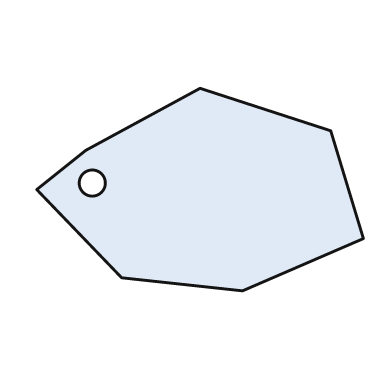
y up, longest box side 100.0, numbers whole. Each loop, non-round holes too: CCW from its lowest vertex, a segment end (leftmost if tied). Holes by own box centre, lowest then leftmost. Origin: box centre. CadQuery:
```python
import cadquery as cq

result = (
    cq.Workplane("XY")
    .moveTo(13.0, -31.0)
    .lineTo(50.0, -15.0)
    .lineTo(40.0, 18.0)
    .lineTo(0.0, 31.0)
    .lineTo(-35.0, 12.0)
    .lineTo(-50.0, 0.0)
    .lineTo(-24.0, -27.0)
    .close()
    .moveTo(-33.0, 2.0)
    .circle(4.0)
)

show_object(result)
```